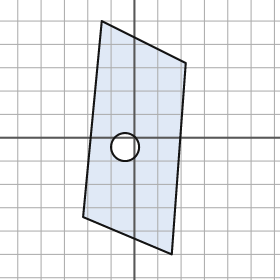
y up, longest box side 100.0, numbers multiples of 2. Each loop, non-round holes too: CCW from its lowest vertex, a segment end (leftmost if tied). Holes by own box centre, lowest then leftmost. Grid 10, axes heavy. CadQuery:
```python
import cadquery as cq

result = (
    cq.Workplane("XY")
    .moveTo(16.0, -50.0)
    .lineTo(22.0, 32.0)
    .lineTo(-14.0, 50.0)
    .lineTo(-22.0, -34.0)
    .close()
    .moveTo(-4.0, -4.0)
    .circle(6.0)
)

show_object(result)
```